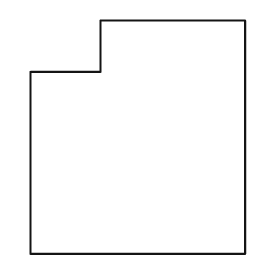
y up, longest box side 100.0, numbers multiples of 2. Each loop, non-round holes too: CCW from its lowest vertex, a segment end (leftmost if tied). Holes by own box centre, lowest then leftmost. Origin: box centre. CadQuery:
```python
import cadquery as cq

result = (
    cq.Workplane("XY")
    .moveTo(-46.0, -50.0)
    .lineTo(46.0, -50.0)
    .lineTo(46.0, 50.0)
    .lineTo(-16.0, 50.0)
    .lineTo(-16.0, 28.0)
    .lineTo(-46.0, 28.0)
    .close()
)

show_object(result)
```